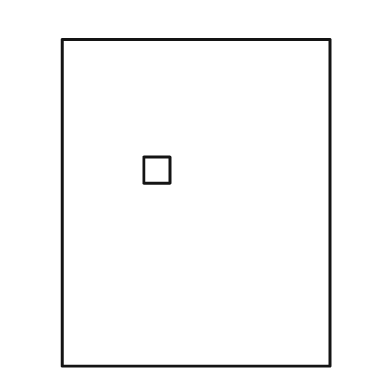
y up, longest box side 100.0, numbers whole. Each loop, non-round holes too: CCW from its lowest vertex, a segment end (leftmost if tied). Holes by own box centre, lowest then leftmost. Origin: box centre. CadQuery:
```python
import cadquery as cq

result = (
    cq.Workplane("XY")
    .moveTo(-41.0, -50.0)
    .lineTo(41.0, -50.0)
    .lineTo(41.0, 50.0)
    .lineTo(-41.0, 50.0)
    .close()
    .moveTo(-16.0, 6.0)
    .lineTo(-8.0, 6.0)
    .lineTo(-8.0, 14.0)
    .lineTo(-16.0, 14.0)
    .close()
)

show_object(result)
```